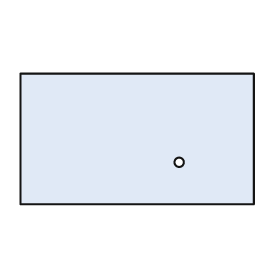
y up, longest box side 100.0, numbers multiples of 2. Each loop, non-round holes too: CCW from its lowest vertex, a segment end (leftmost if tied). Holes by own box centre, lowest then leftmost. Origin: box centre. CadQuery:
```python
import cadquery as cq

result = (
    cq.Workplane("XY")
    .moveTo(-50.0, -28.0)
    .lineTo(50.0, -28.0)
    .lineTo(50.0, 28.0)
    .lineTo(-50.0, 28.0)
    .close()
    .moveTo(18.0, -10.0)
    .circle(2.0)
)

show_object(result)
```